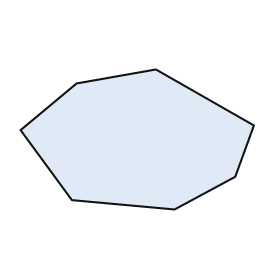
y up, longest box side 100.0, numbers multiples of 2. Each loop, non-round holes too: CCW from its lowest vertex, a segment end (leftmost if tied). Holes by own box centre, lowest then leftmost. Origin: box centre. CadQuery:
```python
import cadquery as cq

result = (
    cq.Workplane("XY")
    .moveTo(16.0, -30.0)
    .lineTo(42.0, -16.0)
    .lineTo(50.0, 6.0)
    .lineTo(8.0, 30.0)
    .lineTo(-26.0, 24.0)
    .lineTo(-50.0, 4.0)
    .lineTo(-28.0, -26.0)
    .close()
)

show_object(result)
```